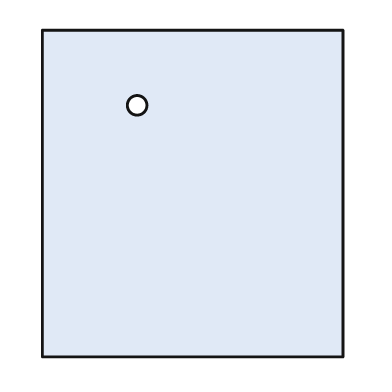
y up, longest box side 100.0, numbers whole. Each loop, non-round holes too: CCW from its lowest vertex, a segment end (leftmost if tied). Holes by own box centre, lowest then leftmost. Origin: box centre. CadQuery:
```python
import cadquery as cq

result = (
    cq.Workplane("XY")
    .moveTo(-46.0, -50.0)
    .lineTo(46.0, -50.0)
    .lineTo(46.0, 50.0)
    .lineTo(-46.0, 50.0)
    .close()
    .moveTo(-17.0, 27.0)
    .circle(3.0)
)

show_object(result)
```